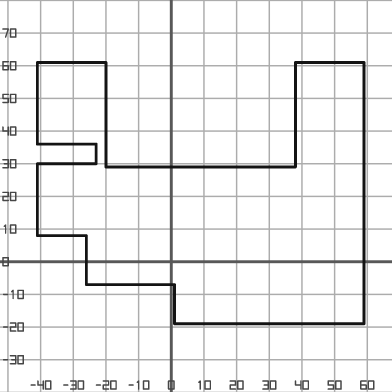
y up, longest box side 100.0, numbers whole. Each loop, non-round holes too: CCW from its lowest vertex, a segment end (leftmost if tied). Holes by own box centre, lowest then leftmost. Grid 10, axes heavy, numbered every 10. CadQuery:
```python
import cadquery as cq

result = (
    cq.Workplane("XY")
    .moveTo(1.0, -19.0)
    .lineTo(59.0, -19.0)
    .lineTo(59.0, 61.0)
    .lineTo(38.0, 61.0)
    .lineTo(38.0, 29.0)
    .lineTo(-20.0, 29.0)
    .lineTo(-20.0, 61.0)
    .lineTo(-41.0, 61.0)
    .lineTo(-41.0, 36.0)
    .lineTo(-23.0, 36.0)
    .lineTo(-23.0, 30.0)
    .lineTo(-41.0, 30.0)
    .lineTo(-41.0, 8.0)
    .lineTo(-26.0, 8.0)
    .lineTo(-26.0, -7.0)
    .lineTo(1.0, -7.0)
    .close()
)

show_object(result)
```